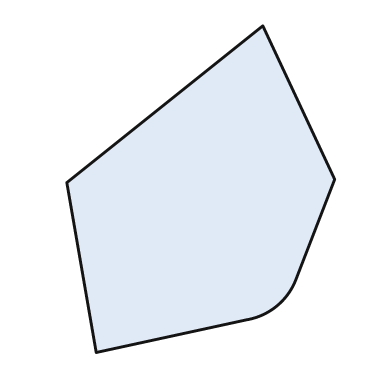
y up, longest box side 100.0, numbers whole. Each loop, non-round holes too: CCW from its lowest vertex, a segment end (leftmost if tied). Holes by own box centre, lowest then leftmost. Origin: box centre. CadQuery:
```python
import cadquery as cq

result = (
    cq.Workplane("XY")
    .moveTo(-32.0, -50.0)
    .lineTo(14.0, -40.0)
    .threePointArc((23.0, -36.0), (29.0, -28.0))
    .lineTo(41.0, 3.0)
    .lineTo(19.0, 50.0)
    .lineTo(-41.0, 2.0)
    .close()
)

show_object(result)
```